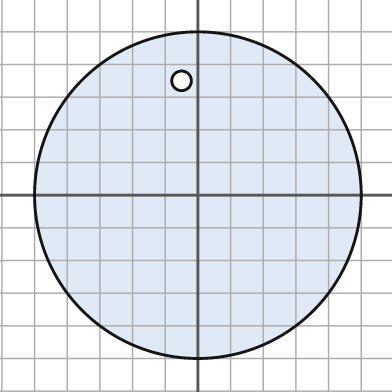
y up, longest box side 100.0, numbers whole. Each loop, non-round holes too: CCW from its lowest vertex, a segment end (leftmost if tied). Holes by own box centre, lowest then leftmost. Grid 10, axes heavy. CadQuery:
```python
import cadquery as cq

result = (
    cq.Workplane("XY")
    .moveTo(0.0, 0.0)
    .circle(50.0)
    .moveTo(-5.0, 35.0)
    .circle(3.0)
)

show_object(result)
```